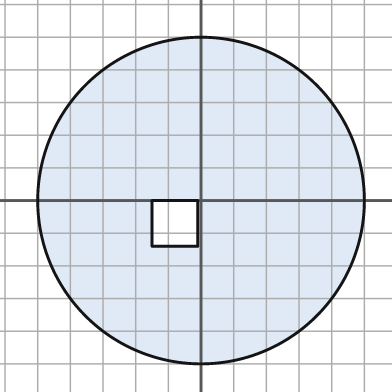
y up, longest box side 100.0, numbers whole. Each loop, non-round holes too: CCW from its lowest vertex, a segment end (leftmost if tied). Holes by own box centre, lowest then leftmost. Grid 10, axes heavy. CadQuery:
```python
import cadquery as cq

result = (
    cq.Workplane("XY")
    .moveTo(0.0, 0.0)
    .circle(50.0)
    .moveTo(-15.0, -14.0)
    .lineTo(-1.0, -14.0)
    .lineTo(-1.0, 0.0)
    .lineTo(-15.0, 0.0)
    .close()
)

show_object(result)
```